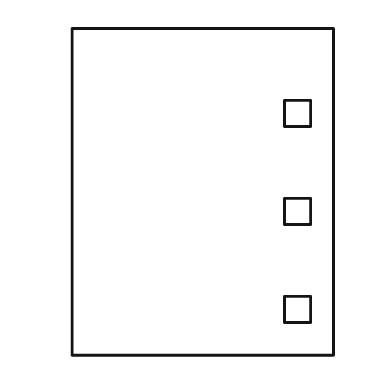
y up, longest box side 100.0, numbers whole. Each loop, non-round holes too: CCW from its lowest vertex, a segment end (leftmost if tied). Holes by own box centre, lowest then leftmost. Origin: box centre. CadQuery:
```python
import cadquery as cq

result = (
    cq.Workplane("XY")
    .moveTo(-40.0, -50.0)
    .lineTo(40.0, -50.0)
    .lineTo(40.0, 50.0)
    .lineTo(-40.0, 50.0)
    .close()
    .moveTo(25.0, -40.0)
    .lineTo(33.0, -40.0)
    .lineTo(33.0, -32.0)
    .lineTo(25.0, -32.0)
    .close()
    .moveTo(25.0, -10.0)
    .lineTo(33.0, -10.0)
    .lineTo(33.0, -2.0)
    .lineTo(25.0, -2.0)
    .close()
    .moveTo(25.0, 20.0)
    .lineTo(33.0, 20.0)
    .lineTo(33.0, 28.0)
    .lineTo(25.0, 28.0)
    .close()
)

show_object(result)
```